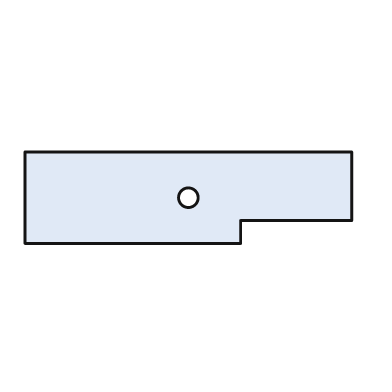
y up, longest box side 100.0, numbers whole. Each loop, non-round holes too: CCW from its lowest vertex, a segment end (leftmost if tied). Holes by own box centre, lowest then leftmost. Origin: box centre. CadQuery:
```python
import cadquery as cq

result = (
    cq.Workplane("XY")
    .moveTo(-50.0, -14.0)
    .lineTo(16.0, -14.0)
    .lineTo(16.0, -7.0)
    .lineTo(50.0, -7.0)
    .lineTo(50.0, 14.0)
    .lineTo(-50.0, 14.0)
    .close()
    .moveTo(0.0, 0.0)
    .circle(3.0)
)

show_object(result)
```